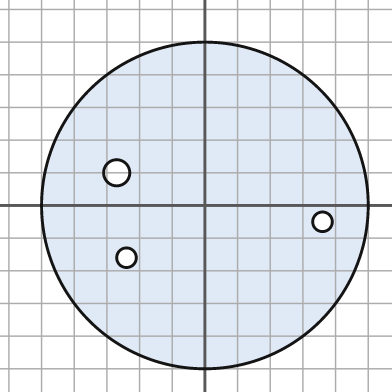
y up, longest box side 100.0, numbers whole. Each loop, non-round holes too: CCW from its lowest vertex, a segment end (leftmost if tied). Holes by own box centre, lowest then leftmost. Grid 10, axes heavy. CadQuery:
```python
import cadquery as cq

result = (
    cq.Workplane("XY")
    .moveTo(0.0, 0.0)
    .circle(50.0)
    .moveTo(-24.0, -16.0)
    .circle(3.0)
    .moveTo(36.0, -5.0)
    .circle(3.0)
    .moveTo(-27.0, 10.0)
    .circle(4.0)
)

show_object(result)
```